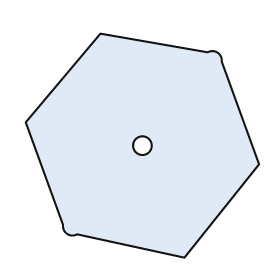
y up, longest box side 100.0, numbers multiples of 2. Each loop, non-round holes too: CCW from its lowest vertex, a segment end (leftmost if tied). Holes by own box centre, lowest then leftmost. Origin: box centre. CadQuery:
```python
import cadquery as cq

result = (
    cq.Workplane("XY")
    .moveTo(18.0, -48.0)
    .lineTo(50.0, -8.0)
    .lineTo(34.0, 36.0)
    .threePointArc((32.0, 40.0), (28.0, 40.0))
    .lineTo(-18.0, 48.0)
    .lineTo(-50.0, 10.0)
    .lineTo(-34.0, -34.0)
    .threePointArc((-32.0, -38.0), (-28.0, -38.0))
    .close()
    .moveTo(0.0, 0.0)
    .circle(4.0)
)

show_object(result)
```